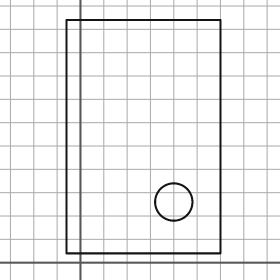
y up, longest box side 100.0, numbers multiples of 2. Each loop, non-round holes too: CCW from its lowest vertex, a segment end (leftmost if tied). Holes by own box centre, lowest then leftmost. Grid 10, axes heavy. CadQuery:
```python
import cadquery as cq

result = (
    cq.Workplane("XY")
    .moveTo(-6.0, 4.0)
    .lineTo(60.0, 4.0)
    .lineTo(60.0, 104.0)
    .lineTo(-6.0, 104.0)
    .close()
    .moveTo(40.0, 26.0)
    .circle(8.0)
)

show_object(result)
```